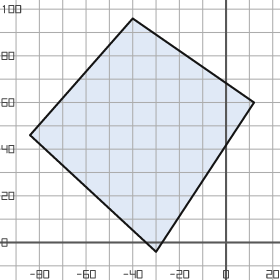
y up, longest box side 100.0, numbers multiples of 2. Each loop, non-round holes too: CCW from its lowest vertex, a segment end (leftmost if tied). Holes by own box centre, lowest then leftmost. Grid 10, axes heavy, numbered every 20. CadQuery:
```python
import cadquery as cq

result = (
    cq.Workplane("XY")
    .moveTo(-30.0, -4.0)
    .lineTo(12.0, 60.0)
    .lineTo(-40.0, 96.0)
    .lineTo(-84.0, 46.0)
    .close()
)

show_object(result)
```